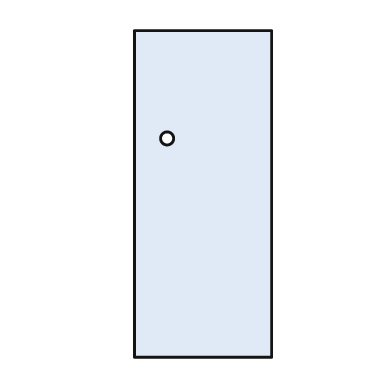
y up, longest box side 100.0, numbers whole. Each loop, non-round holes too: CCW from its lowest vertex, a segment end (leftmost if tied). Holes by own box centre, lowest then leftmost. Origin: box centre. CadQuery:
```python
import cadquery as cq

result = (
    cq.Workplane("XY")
    .moveTo(-21.0, -50.0)
    .lineTo(21.0, -50.0)
    .lineTo(21.0, 50.0)
    .lineTo(-21.0, 50.0)
    .close()
    .moveTo(-11.0, 17.0)
    .circle(2.0)
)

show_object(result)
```